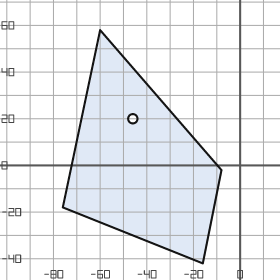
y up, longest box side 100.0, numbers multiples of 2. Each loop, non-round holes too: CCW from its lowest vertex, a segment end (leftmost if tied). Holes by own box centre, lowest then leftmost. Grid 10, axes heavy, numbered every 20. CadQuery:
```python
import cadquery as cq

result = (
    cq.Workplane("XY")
    .moveTo(-16.0, -42.0)
    .lineTo(-8.0, -2.0)
    .lineTo(-60.0, 58.0)
    .lineTo(-76.0, -18.0)
    .close()
    .moveTo(-46.0, 20.0)
    .circle(2.0)
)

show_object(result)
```